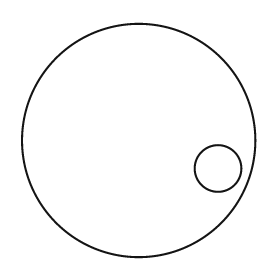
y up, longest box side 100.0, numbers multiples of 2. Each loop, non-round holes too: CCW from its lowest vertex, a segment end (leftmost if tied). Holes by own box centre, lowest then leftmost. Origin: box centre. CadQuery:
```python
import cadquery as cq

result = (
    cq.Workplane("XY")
    .moveTo(0.0, 0.0)
    .circle(50.0)
    .moveTo(34.0, -12.0)
    .circle(10.0)
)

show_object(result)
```